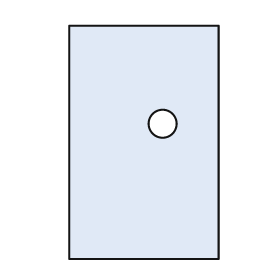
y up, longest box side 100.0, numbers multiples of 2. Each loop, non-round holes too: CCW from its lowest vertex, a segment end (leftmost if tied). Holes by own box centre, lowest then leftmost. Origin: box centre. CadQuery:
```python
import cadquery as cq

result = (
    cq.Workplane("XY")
    .moveTo(-32.0, -50.0)
    .lineTo(32.0, -50.0)
    .lineTo(32.0, 50.0)
    .lineTo(-32.0, 50.0)
    .close()
    .moveTo(8.0, 8.0)
    .circle(6.0)
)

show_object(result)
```